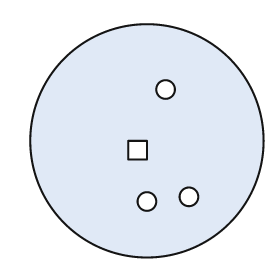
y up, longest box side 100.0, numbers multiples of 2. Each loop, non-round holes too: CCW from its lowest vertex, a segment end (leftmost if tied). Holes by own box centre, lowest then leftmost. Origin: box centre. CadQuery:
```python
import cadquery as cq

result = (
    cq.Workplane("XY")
    .moveTo(0.0, 0.0)
    .circle(50.0)
    .moveTo(0.0, -26.0)
    .circle(4.0)
    .moveTo(18.0, -24.0)
    .circle(4.0)
    .moveTo(-8.0, -8.0)
    .lineTo(0.0, -8.0)
    .lineTo(0.0, 0.0)
    .lineTo(-8.0, 0.0)
    .close()
    .moveTo(8.0, 22.0)
    .circle(4.0)
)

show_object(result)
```